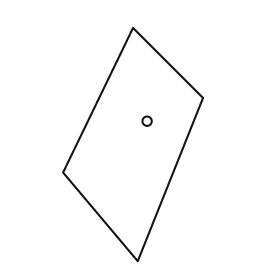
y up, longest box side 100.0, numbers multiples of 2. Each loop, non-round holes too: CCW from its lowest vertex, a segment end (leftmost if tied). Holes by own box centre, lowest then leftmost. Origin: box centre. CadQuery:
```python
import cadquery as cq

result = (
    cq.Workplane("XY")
    .moveTo(2.0, -50.0)
    .lineTo(30.0, 20.0)
    .lineTo(0.0, 50.0)
    .lineTo(-30.0, -12.0)
    .close()
    .moveTo(6.0, 10.0)
    .circle(2.0)
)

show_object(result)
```